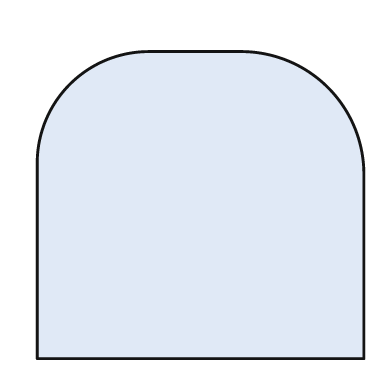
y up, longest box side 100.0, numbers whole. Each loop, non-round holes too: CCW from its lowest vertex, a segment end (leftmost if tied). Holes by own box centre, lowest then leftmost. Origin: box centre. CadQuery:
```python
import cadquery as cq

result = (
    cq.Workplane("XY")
    .moveTo(-50.0, -47.0)
    .lineTo(50.0, -47.0)
    .lineTo(50.0, 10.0)
    .threePointArc((39.0, 36.0), (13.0, 47.0))
    .lineTo(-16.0, 47.0)
    .threePointArc((-40.0, 37.0), (-50.0, 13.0))
    .close()
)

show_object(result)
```